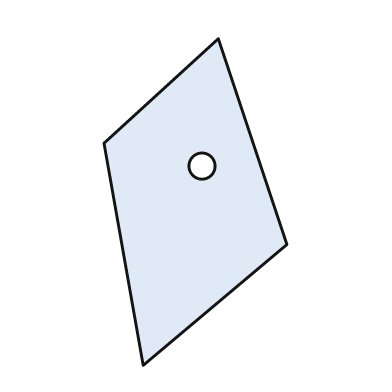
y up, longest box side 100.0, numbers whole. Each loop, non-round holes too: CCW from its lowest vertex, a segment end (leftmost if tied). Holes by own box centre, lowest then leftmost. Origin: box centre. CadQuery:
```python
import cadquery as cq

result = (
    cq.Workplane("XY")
    .moveTo(-16.0, -50.0)
    .lineTo(28.0, -13.0)
    .lineTo(7.0, 50.0)
    .lineTo(-28.0, 18.0)
    .close()
    .moveTo(2.0, 11.0)
    .circle(4.0)
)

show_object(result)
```